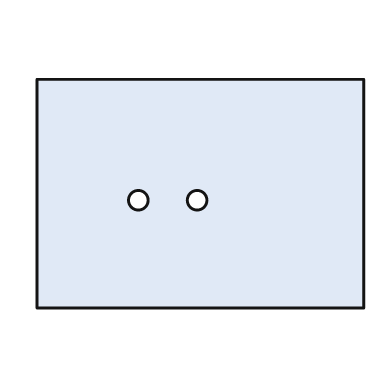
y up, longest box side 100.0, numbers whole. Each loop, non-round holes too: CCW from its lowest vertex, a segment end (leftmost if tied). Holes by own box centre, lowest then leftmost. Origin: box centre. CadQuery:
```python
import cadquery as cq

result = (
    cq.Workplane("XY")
    .moveTo(-50.0, -35.0)
    .lineTo(50.0, -35.0)
    .lineTo(50.0, 35.0)
    .lineTo(-50.0, 35.0)
    .close()
    .moveTo(-19.0, -2.0)
    .circle(3.0)
    .moveTo(-1.0, -2.0)
    .circle(3.0)
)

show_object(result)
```